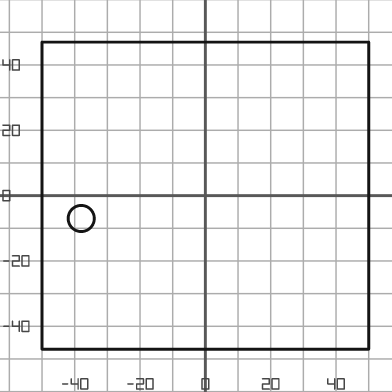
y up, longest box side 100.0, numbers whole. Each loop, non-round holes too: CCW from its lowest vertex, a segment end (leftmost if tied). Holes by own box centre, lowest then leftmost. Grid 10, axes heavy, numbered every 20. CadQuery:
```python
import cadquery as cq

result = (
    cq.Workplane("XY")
    .moveTo(-50.0, -47.0)
    .lineTo(50.0, -47.0)
    .lineTo(50.0, 47.0)
    .lineTo(-50.0, 47.0)
    .close()
    .moveTo(-38.0, -7.0)
    .circle(4.0)
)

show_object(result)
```